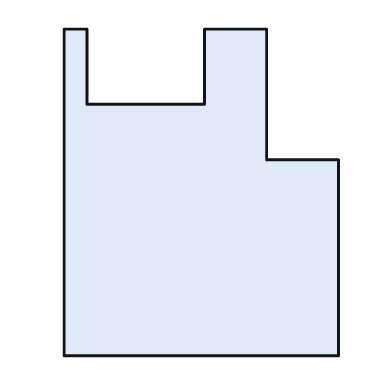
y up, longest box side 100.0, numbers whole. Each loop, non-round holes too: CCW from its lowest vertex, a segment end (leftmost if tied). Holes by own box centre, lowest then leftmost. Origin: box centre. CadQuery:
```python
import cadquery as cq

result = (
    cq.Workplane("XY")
    .moveTo(-42.0, -50.0)
    .lineTo(42.0, -50.0)
    .lineTo(42.0, 10.0)
    .lineTo(20.0, 10.0)
    .lineTo(20.0, 50.0)
    .lineTo(1.0, 50.0)
    .lineTo(1.0, 27.0)
    .lineTo(-35.0, 27.0)
    .lineTo(-35.0, 50.0)
    .lineTo(-42.0, 50.0)
    .close()
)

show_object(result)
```